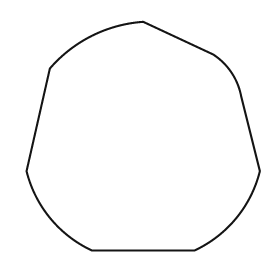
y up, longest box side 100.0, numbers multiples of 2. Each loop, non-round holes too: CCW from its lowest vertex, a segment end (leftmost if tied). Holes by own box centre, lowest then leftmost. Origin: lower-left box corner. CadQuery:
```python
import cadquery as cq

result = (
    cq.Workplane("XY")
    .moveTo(28.0, 0.0)
    .lineTo(72.0, 0.0)
    .threePointArc((90.0, 14.0), (100.0, 34.0))
    .lineTo(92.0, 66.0)
    .threePointArc((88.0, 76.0), (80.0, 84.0))
    .lineTo(50.0, 98.0)
    .threePointArc((28.0, 92.0), (10.0, 78.0))
    .lineTo(0.0, 34.0)
    .threePointArc((10.0, 14.0), (28.0, 0.0))
    .close()
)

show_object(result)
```